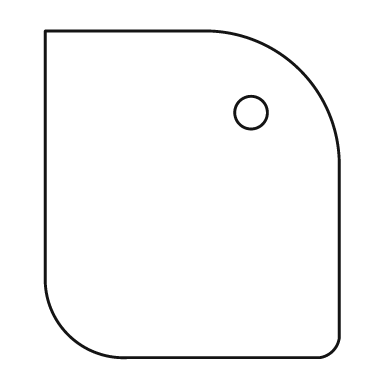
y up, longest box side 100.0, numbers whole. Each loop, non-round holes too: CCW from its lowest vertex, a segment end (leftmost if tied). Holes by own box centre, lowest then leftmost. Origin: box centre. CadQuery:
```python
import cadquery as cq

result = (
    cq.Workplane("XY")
    .moveTo(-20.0, -50.0)
    .lineTo(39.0, -50.0)
    .threePointArc((43.0, -48.0), (45.0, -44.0))
    .lineTo(45.0, 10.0)
    .threePointArc((33.0, 38.0), (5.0, 50.0))
    .lineTo(-45.0, 50.0)
    .lineTo(-45.0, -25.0)
    .threePointArc((-38.0, -43.0), (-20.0, -50.0))
    .close()
    .moveTo(18.0, 25.0)
    .circle(5.0)
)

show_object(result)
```